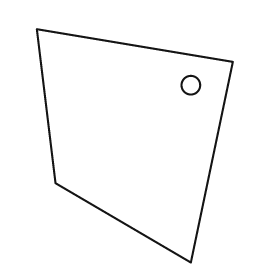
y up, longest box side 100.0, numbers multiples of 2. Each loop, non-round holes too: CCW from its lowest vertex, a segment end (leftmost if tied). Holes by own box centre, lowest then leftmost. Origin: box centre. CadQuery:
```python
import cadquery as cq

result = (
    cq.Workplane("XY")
    .moveTo(24.0, -50.0)
    .lineTo(42.0, 36.0)
    .lineTo(-42.0, 50.0)
    .lineTo(-34.0, -16.0)
    .close()
    .moveTo(24.0, 26.0)
    .circle(4.0)
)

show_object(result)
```